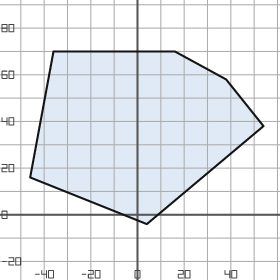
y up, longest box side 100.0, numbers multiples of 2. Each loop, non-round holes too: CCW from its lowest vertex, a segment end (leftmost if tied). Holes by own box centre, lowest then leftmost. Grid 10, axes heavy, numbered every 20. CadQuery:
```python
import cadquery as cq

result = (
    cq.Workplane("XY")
    .moveTo(4.0, -4.0)
    .lineTo(54.0, 38.0)
    .lineTo(38.0, 58.0)
    .lineTo(16.0, 70.0)
    .lineTo(-36.0, 70.0)
    .lineTo(-46.0, 16.0)
    .close()
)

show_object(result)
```